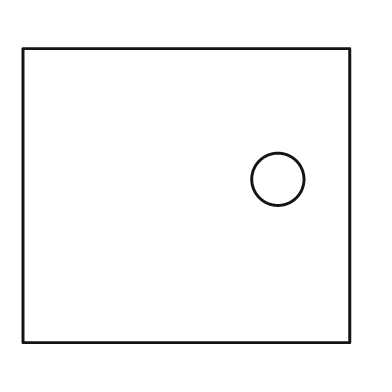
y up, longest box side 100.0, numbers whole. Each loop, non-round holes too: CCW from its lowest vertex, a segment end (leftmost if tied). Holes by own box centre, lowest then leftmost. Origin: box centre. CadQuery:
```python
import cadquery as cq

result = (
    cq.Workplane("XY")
    .moveTo(-50.0, -45.0)
    .lineTo(50.0, -45.0)
    .lineTo(50.0, 45.0)
    .lineTo(-50.0, 45.0)
    .close()
    .moveTo(28.0, 5.0)
    .circle(8.0)
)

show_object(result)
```